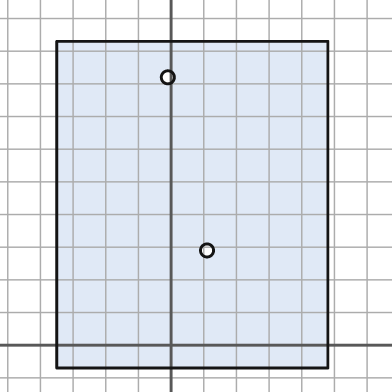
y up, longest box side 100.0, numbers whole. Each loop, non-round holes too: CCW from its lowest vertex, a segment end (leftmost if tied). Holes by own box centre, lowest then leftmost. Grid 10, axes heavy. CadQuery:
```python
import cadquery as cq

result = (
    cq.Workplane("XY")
    .moveTo(-35.0, -7.0)
    .lineTo(48.0, -7.0)
    .lineTo(48.0, 93.0)
    .lineTo(-35.0, 93.0)
    .close()
    .moveTo(11.0, 29.0)
    .circle(2.0)
    .moveTo(-1.0, 82.0)
    .circle(2.0)
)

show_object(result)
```